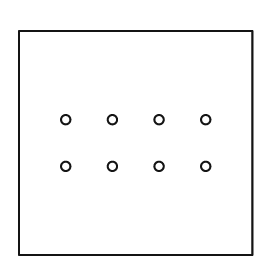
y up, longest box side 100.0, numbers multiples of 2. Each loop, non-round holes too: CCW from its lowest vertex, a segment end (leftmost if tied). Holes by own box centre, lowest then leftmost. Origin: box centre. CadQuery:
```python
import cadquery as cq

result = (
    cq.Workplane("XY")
    .moveTo(-50.0, -48.0)
    .lineTo(50.0, -48.0)
    .lineTo(50.0, 48.0)
    .lineTo(-50.0, 48.0)
    .close()
    .moveTo(-30.0, -10.0)
    .circle(2.0)
    .moveTo(-10.0, -10.0)
    .circle(2.0)
    .moveTo(10.0, -10.0)
    .circle(2.0)
    .moveTo(30.0, -10.0)
    .circle(2.0)
    .moveTo(-30.0, 10.0)
    .circle(2.0)
    .moveTo(-10.0, 10.0)
    .circle(2.0)
    .moveTo(10.0, 10.0)
    .circle(2.0)
    .moveTo(30.0, 10.0)
    .circle(2.0)
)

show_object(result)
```